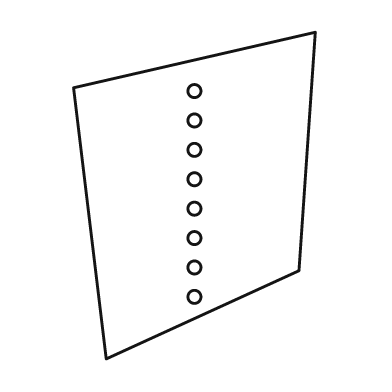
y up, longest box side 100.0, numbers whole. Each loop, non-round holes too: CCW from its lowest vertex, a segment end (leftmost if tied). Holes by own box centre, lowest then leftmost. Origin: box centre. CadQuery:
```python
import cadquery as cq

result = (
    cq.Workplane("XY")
    .moveTo(-27.0, -50.0)
    .lineTo(32.0, -23.0)
    .lineTo(37.0, 50.0)
    .lineTo(-37.0, 33.0)
    .close()
    .moveTo(0.0, -31.0)
    .circle(2.0)
    .moveTo(0.0, -22.0)
    .circle(2.0)
    .moveTo(0.0, -13.0)
    .circle(2.0)
    .moveTo(0.0, -4.0)
    .circle(2.0)
    .moveTo(0.0, 5.0)
    .circle(2.0)
    .moveTo(0.0, 14.0)
    .circle(2.0)
    .moveTo(0.0, 23.0)
    .circle(2.0)
    .moveTo(0.0, 32.0)
    .circle(2.0)
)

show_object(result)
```